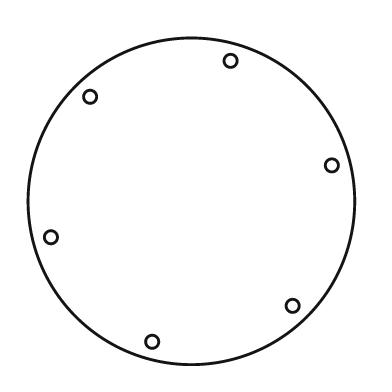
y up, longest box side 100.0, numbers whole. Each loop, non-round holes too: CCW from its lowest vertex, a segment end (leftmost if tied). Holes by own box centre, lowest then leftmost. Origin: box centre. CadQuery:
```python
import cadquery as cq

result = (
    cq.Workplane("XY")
    .moveTo(0.0, 0.0)
    .circle(50.0)
    .moveTo(-12.0, -43.0)
    .circle(2.0)
    .moveTo(31.0, -32.0)
    .circle(2.0)
    .moveTo(-43.0, -11.0)
    .circle(2.0)
    .moveTo(43.0, 11.0)
    .circle(2.0)
    .moveTo(-31.0, 32.0)
    .circle(2.0)
    .moveTo(12.0, 43.0)
    .circle(2.0)
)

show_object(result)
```